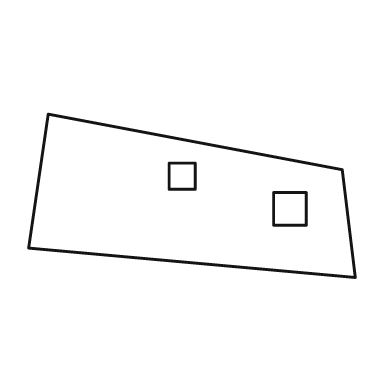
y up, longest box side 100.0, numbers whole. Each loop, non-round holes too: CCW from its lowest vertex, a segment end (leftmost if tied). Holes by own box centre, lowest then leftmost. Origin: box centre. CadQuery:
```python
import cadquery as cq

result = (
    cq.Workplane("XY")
    .moveTo(50.0, -25.0)
    .lineTo(46.0, 8.0)
    .lineTo(-44.0, 25.0)
    .lineTo(-50.0, -16.0)
    .close()
    .moveTo(25.0, -9.0)
    .lineTo(35.0, -9.0)
    .lineTo(35.0, 1.0)
    .lineTo(25.0, 1.0)
    .close()
    .moveTo(-7.0, 2.0)
    .lineTo(1.0, 2.0)
    .lineTo(1.0, 10.0)
    .lineTo(-7.0, 10.0)
    .close()
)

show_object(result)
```